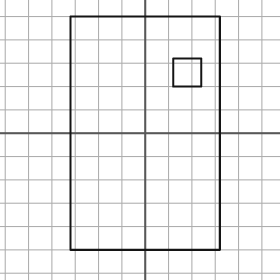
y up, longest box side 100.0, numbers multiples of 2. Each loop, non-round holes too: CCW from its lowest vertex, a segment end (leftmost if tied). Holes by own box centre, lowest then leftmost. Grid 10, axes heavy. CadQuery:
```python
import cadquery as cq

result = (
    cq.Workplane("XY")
    .moveTo(-32.0, -50.0)
    .lineTo(32.0, -50.0)
    .lineTo(32.0, 50.0)
    .lineTo(-32.0, 50.0)
    .close()
    .moveTo(12.0, 20.0)
    .lineTo(24.0, 20.0)
    .lineTo(24.0, 32.0)
    .lineTo(12.0, 32.0)
    .close()
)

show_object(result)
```